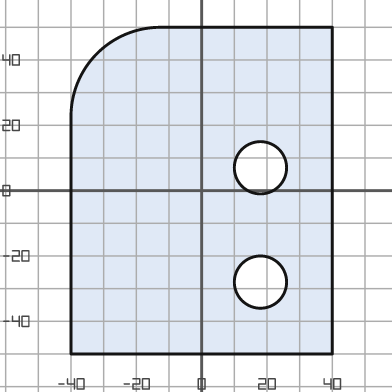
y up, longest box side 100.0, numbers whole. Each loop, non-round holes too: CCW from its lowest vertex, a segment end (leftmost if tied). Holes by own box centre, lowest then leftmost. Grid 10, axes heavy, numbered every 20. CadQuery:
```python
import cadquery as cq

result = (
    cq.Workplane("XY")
    .moveTo(-40.0, -50.0)
    .lineTo(40.0, -50.0)
    .lineTo(40.0, 50.0)
    .lineTo(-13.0, 50.0)
    .threePointArc((-32.0, 42.0), (-40.0, 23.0))
    .close()
    .moveTo(18.0, -28.0)
    .circle(8.0)
    .moveTo(18.0, 7.0)
    .circle(8.0)
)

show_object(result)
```